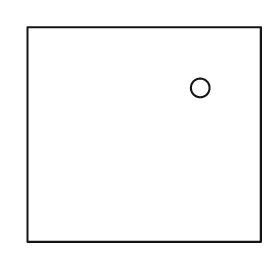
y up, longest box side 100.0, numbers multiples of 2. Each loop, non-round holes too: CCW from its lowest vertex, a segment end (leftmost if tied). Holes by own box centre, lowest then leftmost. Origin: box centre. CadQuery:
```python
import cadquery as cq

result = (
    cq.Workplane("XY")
    .moveTo(-50.0, -46.0)
    .lineTo(50.0, -46.0)
    .lineTo(50.0, 46.0)
    .lineTo(-50.0, 46.0)
    .close()
    .moveTo(24.0, 20.0)
    .circle(4.0)
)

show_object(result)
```